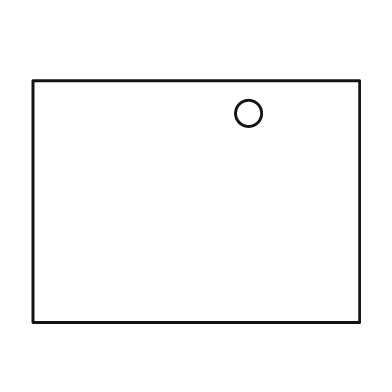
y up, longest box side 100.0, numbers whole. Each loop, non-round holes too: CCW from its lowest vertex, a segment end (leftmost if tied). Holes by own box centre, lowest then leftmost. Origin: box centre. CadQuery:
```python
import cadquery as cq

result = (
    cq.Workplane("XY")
    .moveTo(-50.0, -37.0)
    .lineTo(50.0, -37.0)
    .lineTo(50.0, 37.0)
    .lineTo(-50.0, 37.0)
    .close()
    .moveTo(16.0, 27.0)
    .circle(4.0)
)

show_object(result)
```